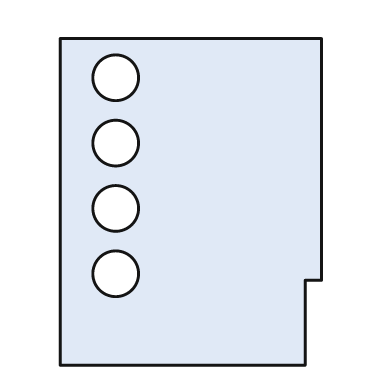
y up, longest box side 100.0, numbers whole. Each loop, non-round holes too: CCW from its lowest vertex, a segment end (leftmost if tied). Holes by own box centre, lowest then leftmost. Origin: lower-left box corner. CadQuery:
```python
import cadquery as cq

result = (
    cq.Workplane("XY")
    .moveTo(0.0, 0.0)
    .lineTo(75.0, 0.0)
    .lineTo(75.0, 26.0)
    .lineTo(80.0, 26.0)
    .lineTo(80.0, 100.0)
    .lineTo(0.0, 100.0)
    .close()
    .moveTo(17.0, 28.0)
    .circle(7.0)
    .moveTo(17.0, 48.0)
    .circle(7.0)
    .moveTo(17.0, 68.0)
    .circle(7.0)
    .moveTo(17.0, 88.0)
    .circle(7.0)
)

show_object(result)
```